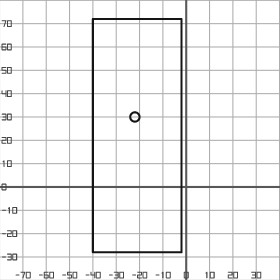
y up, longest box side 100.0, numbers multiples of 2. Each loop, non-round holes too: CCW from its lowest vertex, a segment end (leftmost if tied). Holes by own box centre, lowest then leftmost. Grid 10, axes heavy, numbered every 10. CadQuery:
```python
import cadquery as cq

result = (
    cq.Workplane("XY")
    .moveTo(-40.0, -28.0)
    .lineTo(-2.0, -28.0)
    .lineTo(-2.0, 72.0)
    .lineTo(-40.0, 72.0)
    .close()
    .moveTo(-22.0, 30.0)
    .circle(2.0)
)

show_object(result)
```